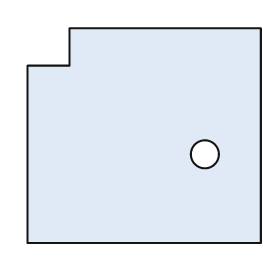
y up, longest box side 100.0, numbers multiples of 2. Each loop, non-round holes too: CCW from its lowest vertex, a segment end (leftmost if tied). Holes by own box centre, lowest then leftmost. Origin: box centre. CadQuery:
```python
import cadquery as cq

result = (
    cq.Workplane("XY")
    .moveTo(-50.0, -46.0)
    .lineTo(50.0, -46.0)
    .lineTo(50.0, 46.0)
    .lineTo(-32.0, 46.0)
    .lineTo(-32.0, 30.0)
    .lineTo(-50.0, 30.0)
    .close()
    .moveTo(26.0, -8.0)
    .circle(6.0)
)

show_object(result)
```